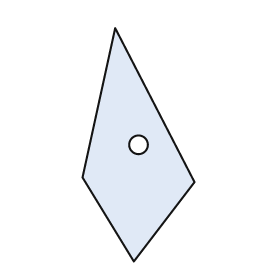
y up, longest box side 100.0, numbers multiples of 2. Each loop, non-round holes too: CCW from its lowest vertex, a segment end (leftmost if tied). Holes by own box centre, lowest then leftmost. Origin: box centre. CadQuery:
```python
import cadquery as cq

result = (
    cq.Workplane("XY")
    .moveTo(-2.0, -50.0)
    .lineTo(24.0, -16.0)
    .lineTo(-10.0, 50.0)
    .lineTo(-24.0, -14.0)
    .close()
    .moveTo(0.0, 0.0)
    .circle(4.0)
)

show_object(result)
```